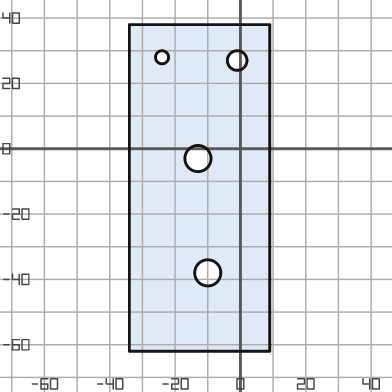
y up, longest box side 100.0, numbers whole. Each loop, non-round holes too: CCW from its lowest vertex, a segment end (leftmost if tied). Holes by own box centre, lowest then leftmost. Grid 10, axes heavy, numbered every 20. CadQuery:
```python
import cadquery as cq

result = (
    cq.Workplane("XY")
    .moveTo(-34.0, -62.0)
    .lineTo(9.0, -62.0)
    .lineTo(9.0, 38.0)
    .lineTo(-34.0, 38.0)
    .close()
    .moveTo(-10.0, -38.0)
    .circle(4.0)
    .moveTo(-13.0, -3.0)
    .circle(4.0)
    .moveTo(-1.0, 27.0)
    .circle(3.0)
    .moveTo(-24.0, 28.0)
    .circle(2.0)
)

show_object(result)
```